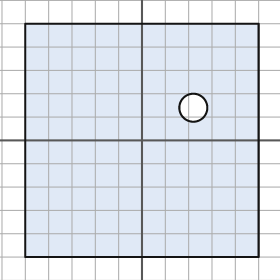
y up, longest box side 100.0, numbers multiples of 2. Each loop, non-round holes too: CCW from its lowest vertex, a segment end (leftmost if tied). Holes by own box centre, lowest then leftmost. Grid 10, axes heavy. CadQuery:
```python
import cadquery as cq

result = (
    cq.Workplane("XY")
    .moveTo(-50.0, -50.0)
    .lineTo(50.0, -50.0)
    .lineTo(50.0, 50.0)
    .lineTo(-50.0, 50.0)
    .close()
    .moveTo(22.0, 14.0)
    .circle(6.0)
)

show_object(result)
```